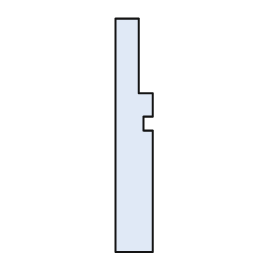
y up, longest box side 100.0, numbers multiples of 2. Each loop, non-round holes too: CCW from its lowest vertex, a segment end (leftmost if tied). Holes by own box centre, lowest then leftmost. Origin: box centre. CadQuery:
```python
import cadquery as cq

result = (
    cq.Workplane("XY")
    .moveTo(-8.0, -50.0)
    .lineTo(8.0, -50.0)
    .lineTo(8.0, 2.0)
    .lineTo(4.0, 2.0)
    .lineTo(4.0, 8.0)
    .lineTo(8.0, 8.0)
    .lineTo(8.0, 18.0)
    .lineTo(2.0, 18.0)
    .lineTo(2.0, 50.0)
    .lineTo(-8.0, 50.0)
    .close()
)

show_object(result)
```